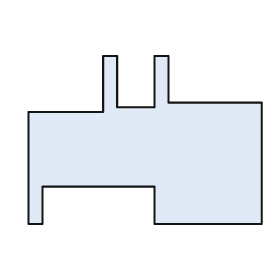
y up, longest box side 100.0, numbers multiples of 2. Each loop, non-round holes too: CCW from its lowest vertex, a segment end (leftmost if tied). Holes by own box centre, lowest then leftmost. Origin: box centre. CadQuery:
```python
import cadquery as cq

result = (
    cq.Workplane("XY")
    .moveTo(-50.0, -36.0)
    .lineTo(-44.0, -36.0)
    .lineTo(-44.0, -20.0)
    .lineTo(4.0, -20.0)
    .lineTo(4.0, -36.0)
    .lineTo(50.0, -36.0)
    .lineTo(50.0, 16.0)
    .lineTo(10.0, 16.0)
    .lineTo(10.0, 36.0)
    .lineTo(4.0, 36.0)
    .lineTo(4.0, 14.0)
    .lineTo(-12.0, 14.0)
    .lineTo(-12.0, 36.0)
    .lineTo(-18.0, 36.0)
    .lineTo(-18.0, 12.0)
    .lineTo(-50.0, 12.0)
    .close()
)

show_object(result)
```